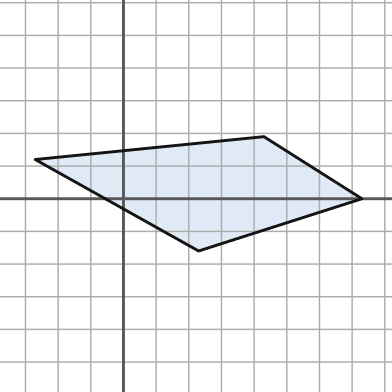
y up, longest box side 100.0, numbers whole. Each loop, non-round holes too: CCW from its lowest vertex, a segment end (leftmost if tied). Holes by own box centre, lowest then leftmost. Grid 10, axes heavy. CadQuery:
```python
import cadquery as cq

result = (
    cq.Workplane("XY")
    .moveTo(23.0, -16.0)
    .lineTo(73.0, 0.0)
    .lineTo(43.0, 19.0)
    .lineTo(-27.0, 12.0)
    .close()
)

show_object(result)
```